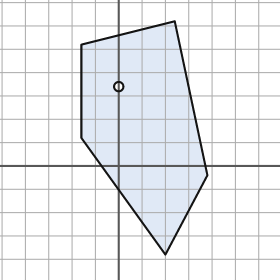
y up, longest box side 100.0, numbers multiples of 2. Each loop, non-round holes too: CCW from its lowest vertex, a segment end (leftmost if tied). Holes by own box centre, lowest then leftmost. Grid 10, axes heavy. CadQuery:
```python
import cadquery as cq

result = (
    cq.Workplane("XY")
    .moveTo(20.0, -38.0)
    .lineTo(38.0, -4.0)
    .lineTo(24.0, 62.0)
    .lineTo(-16.0, 52.0)
    .lineTo(-16.0, 12.0)
    .close()
    .moveTo(0.0, 34.0)
    .circle(2.0)
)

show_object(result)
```